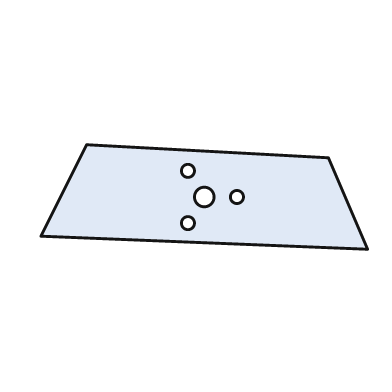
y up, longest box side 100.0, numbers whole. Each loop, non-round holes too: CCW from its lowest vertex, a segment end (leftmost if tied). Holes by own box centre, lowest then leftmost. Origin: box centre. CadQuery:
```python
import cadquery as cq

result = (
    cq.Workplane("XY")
    .moveTo(50.0, -16.0)
    .lineTo(38.0, 12.0)
    .lineTo(-36.0, 16.0)
    .lineTo(-50.0, -12.0)
    .close()
    .moveTo(-5.0, -8.0)
    .circle(2.0)
    .moveTo(0.0, 0.0)
    .circle(3.0)
    .moveTo(10.0, 0.0)
    .circle(2.0)
    .moveTo(-5.0, 8.0)
    .circle(2.0)
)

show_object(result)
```